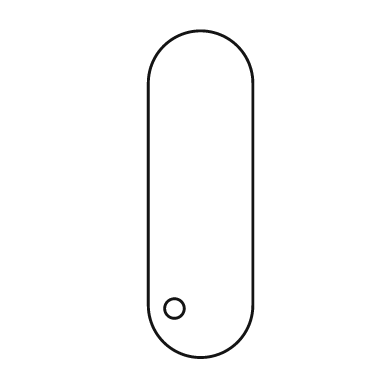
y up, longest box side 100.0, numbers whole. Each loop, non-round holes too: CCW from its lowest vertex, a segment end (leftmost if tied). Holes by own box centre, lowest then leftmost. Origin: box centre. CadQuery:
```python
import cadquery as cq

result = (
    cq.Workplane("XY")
    .moveTo(-16.0, -34.0)
    .threePointArc((0.0, -50.0), (16.0, -34.0))
    .lineTo(16.0, 34.0)
    .threePointArc((0.0, 50.0), (-16.0, 34.0))
    .close()
    .moveTo(-8.0, -35.0)
    .circle(3.0)
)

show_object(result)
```